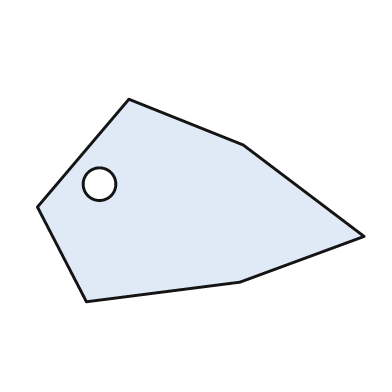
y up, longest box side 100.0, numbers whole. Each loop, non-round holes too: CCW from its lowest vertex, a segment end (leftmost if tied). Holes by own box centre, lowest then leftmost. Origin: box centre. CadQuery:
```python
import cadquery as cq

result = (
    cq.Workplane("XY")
    .moveTo(-35.0, -31.0)
    .lineTo(12.0, -25.0)
    .lineTo(50.0, -11.0)
    .lineTo(13.0, 17.0)
    .lineTo(-22.0, 31.0)
    .lineTo(-50.0, -2.0)
    .close()
    .moveTo(-31.0, 5.0)
    .circle(5.0)
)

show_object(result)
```